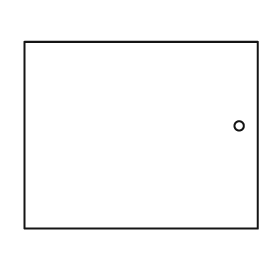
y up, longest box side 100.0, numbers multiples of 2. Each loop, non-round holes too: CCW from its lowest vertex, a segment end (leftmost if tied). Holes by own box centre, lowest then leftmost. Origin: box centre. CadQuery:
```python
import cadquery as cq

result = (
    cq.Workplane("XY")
    .moveTo(-50.0, -40.0)
    .lineTo(50.0, -40.0)
    .lineTo(50.0, 40.0)
    .lineTo(-50.0, 40.0)
    .close()
    .moveTo(42.0, 4.0)
    .circle(2.0)
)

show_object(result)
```